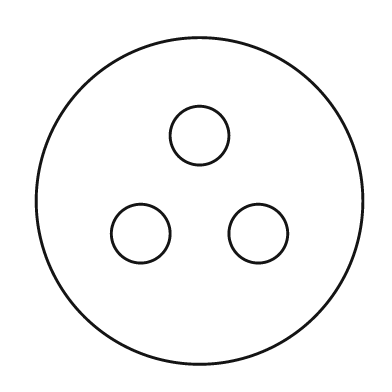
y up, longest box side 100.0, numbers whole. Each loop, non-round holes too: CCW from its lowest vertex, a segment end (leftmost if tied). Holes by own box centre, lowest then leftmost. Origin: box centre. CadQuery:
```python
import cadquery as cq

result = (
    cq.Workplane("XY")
    .moveTo(0.0, 0.0)
    .circle(50.0)
    .moveTo(-18.0, -10.0)
    .circle(9.0)
    .moveTo(18.0, -10.0)
    .circle(9.0)
    .moveTo(0.0, 20.0)
    .circle(9.0)
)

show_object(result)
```